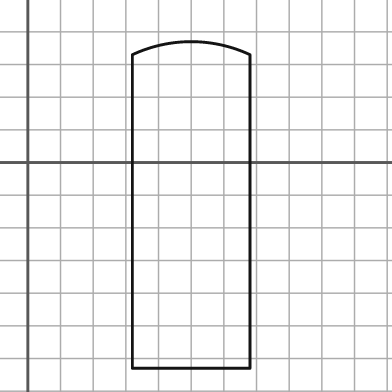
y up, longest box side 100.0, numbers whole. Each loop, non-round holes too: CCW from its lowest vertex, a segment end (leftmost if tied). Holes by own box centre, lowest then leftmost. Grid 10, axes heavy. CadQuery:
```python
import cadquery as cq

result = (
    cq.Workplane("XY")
    .moveTo(32.0, -63.0)
    .lineTo(68.0, -63.0)
    .lineTo(68.0, 33.0)
    .threePointArc((50.0, 37.0), (32.0, 33.0))
    .close()
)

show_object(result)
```